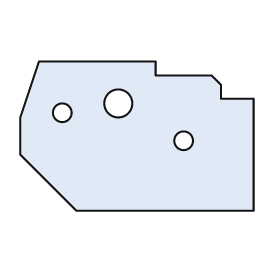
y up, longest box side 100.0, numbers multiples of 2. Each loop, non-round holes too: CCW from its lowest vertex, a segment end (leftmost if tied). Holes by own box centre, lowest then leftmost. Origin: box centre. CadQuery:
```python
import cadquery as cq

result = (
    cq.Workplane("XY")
    .moveTo(-26.0, -32.0)
    .lineTo(50.0, -32.0)
    .lineTo(50.0, 16.0)
    .lineTo(36.0, 16.0)
    .lineTo(36.0, 22.0)
    .lineTo(32.0, 26.0)
    .lineTo(8.0, 26.0)
    .lineTo(8.0, 32.0)
    .lineTo(-42.0, 32.0)
    .lineTo(-50.0, 8.0)
    .lineTo(-50.0, -8.0)
    .close()
    .moveTo(20.0, -2.0)
    .circle(4.0)
    .moveTo(-32.0, 10.0)
    .circle(4.0)
    .moveTo(-8.0, 14.0)
    .circle(6.0)
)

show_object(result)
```